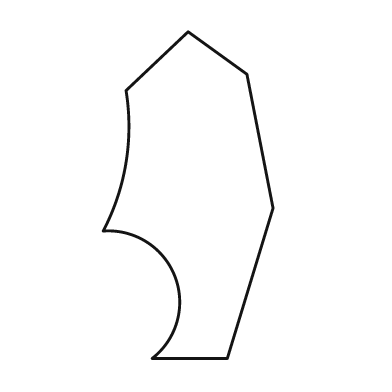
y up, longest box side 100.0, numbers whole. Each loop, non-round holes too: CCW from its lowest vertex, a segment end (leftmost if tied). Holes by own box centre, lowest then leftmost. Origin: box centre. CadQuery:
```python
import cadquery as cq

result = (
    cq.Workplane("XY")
    .moveTo(-11.0, -50.0)
    .lineTo(12.0, -50.0)
    .lineTo(26.0, -4.0)
    .lineTo(18.0, 37.0)
    .lineTo(0.0, 50.0)
    .lineTo(-19.0, 32.0)
    .threePointArc((-19.0, 10.0), (-26.0, -11.0))
    .threePointArc((-4.0, -25.0), (-11.0, -50.0))
    .close()
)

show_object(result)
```